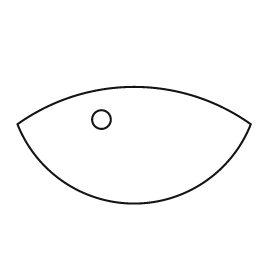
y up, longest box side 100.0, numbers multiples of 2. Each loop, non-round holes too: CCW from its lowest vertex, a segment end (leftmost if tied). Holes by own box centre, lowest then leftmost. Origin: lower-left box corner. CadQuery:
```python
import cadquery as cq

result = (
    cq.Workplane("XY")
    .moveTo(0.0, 34.0)
    .threePointArc((50.0, 0.0), (100.0, 34.0))
    .threePointArc((50.0, 50.0), (0.0, 34.0))
    .close()
    .moveTo(36.0, 36.0)
    .circle(4.0)
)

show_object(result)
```